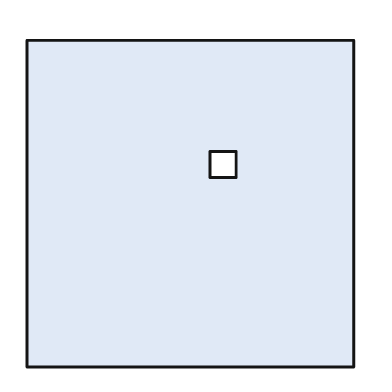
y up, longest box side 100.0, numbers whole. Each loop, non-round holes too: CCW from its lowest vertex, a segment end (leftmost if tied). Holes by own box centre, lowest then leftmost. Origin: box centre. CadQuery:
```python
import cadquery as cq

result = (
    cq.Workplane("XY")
    .moveTo(-50.0, -50.0)
    .lineTo(50.0, -50.0)
    .lineTo(50.0, 50.0)
    .lineTo(-50.0, 50.0)
    .close()
    .moveTo(6.0, 8.0)
    .lineTo(14.0, 8.0)
    .lineTo(14.0, 16.0)
    .lineTo(6.0, 16.0)
    .close()
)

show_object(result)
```